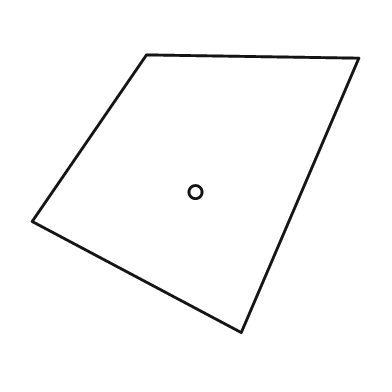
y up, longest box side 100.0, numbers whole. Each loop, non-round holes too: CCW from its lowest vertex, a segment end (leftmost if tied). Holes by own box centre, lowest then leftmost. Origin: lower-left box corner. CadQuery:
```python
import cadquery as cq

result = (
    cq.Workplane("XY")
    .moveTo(64.0, 0.0)
    .lineTo(100.0, 84.0)
    .lineTo(35.0, 85.0)
    .lineTo(0.0, 34.0)
    .close()
    .moveTo(50.0, 43.0)
    .circle(2.0)
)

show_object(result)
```